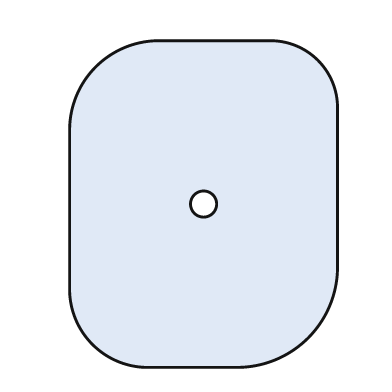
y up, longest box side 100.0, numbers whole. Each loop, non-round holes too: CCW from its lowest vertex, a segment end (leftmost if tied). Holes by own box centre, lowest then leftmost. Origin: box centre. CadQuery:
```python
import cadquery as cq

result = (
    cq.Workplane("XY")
    .moveTo(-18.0, -50.0)
    .lineTo(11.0, -50.0)
    .threePointArc((32.0, -41.0), (41.0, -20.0))
    .lineTo(41.0, 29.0)
    .threePointArc((35.0, 44.0), (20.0, 50.0))
    .lineTo(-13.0, 50.0)
    .threePointArc((-33.0, 42.0), (-41.0, 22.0))
    .lineTo(-41.0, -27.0)
    .threePointArc((-34.0, -43.0), (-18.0, -50.0))
    .close()
    .moveTo(0.0, 0.0)
    .circle(4.0)
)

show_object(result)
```